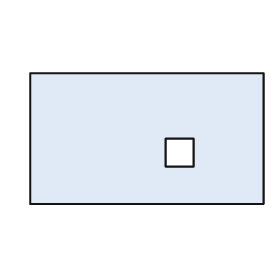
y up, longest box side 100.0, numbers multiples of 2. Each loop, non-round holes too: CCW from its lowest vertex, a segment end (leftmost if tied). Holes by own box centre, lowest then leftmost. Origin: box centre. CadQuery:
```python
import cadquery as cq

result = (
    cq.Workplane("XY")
    .moveTo(-50.0, -28.0)
    .lineTo(50.0, -28.0)
    .lineTo(50.0, 28.0)
    .lineTo(-50.0, 28.0)
    .close()
    .moveTo(8.0, -12.0)
    .lineTo(20.0, -12.0)
    .lineTo(20.0, 0.0)
    .lineTo(8.0, 0.0)
    .close()
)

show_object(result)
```